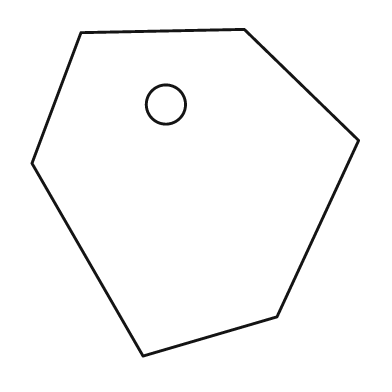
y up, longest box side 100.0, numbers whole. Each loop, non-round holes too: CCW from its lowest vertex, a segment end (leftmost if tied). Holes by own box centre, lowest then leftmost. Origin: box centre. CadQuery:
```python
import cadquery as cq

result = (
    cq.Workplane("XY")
    .moveTo(-16.0, -50.0)
    .lineTo(25.0, -38.0)
    .lineTo(50.0, 16.0)
    .lineTo(15.0, 50.0)
    .lineTo(-35.0, 49.0)
    .lineTo(-50.0, 9.0)
    .close()
    .moveTo(-9.0, 27.0)
    .circle(6.0)
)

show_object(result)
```